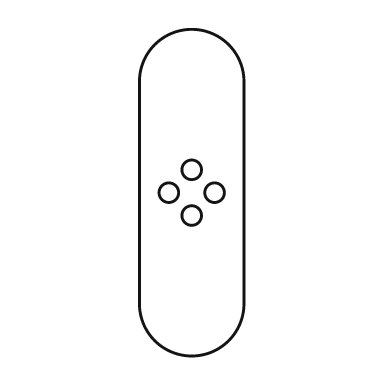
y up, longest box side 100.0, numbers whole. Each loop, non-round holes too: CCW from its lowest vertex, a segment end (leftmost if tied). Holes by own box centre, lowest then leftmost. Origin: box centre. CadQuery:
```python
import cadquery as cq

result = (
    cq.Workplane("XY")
    .moveTo(-16.0, -34.0)
    .threePointArc((0.0, -50.0), (16.0, -34.0))
    .lineTo(16.0, 34.0)
    .threePointArc((0.0, 50.0), (-16.0, 34.0))
    .close()
    .moveTo(0.0, -7.0)
    .circle(3.0)
    .moveTo(-7.0, 0.0)
    .circle(3.0)
    .moveTo(7.0, 0.0)
    .circle(3.0)
    .moveTo(0.0, 7.0)
    .circle(3.0)
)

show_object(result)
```